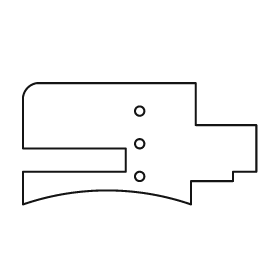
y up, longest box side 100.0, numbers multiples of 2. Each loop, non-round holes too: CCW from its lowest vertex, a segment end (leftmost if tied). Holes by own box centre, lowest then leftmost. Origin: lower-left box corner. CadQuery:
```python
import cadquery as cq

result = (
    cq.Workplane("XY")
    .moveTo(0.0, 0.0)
    .threePointArc((36.0, 6.0), (72.0, 0.0))
    .lineTo(72.0, 10.0)
    .lineTo(90.0, 10.0)
    .lineTo(90.0, 14.0)
    .lineTo(100.0, 14.0)
    .lineTo(100.0, 34.0)
    .lineTo(74.0, 34.0)
    .lineTo(74.0, 52.0)
    .lineTo(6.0, 52.0)
    .threePointArc((2.0, 50.0), (0.0, 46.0))
    .lineTo(0.0, 24.0)
    .lineTo(44.0, 24.0)
    .lineTo(44.0, 14.0)
    .lineTo(0.0, 14.0)
    .close()
    .moveTo(50.0, 12.0)
    .circle(2.0)
    .moveTo(50.0, 26.0)
    .circle(2.0)
    .moveTo(50.0, 40.0)
    .circle(2.0)
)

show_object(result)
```